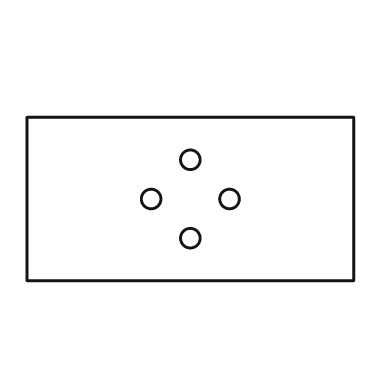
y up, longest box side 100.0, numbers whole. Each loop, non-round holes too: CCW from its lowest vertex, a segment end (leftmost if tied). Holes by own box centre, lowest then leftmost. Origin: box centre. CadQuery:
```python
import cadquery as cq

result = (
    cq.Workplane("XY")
    .moveTo(-50.0, -25.0)
    .lineTo(50.0, -25.0)
    .lineTo(50.0, 25.0)
    .lineTo(-50.0, 25.0)
    .close()
    .moveTo(0.0, -12.0)
    .circle(3.0)
    .moveTo(-12.0, 0.0)
    .circle(3.0)
    .moveTo(12.0, 0.0)
    .circle(3.0)
    .moveTo(0.0, 12.0)
    .circle(3.0)
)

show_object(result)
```